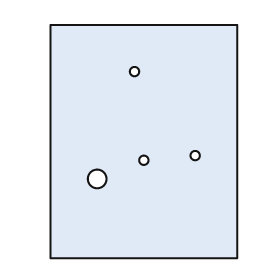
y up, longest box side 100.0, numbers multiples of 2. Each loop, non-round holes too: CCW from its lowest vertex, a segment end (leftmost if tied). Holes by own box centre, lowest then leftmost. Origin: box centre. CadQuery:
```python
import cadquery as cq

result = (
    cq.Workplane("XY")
    .moveTo(-40.0, -50.0)
    .lineTo(40.0, -50.0)
    .lineTo(40.0, 50.0)
    .lineTo(-40.0, 50.0)
    .close()
    .moveTo(-20.0, -16.0)
    .circle(4.0)
    .moveTo(0.0, -8.0)
    .circle(2.0)
    .moveTo(22.0, -6.0)
    .circle(2.0)
    .moveTo(-4.0, 30.0)
    .circle(2.0)
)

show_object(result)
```